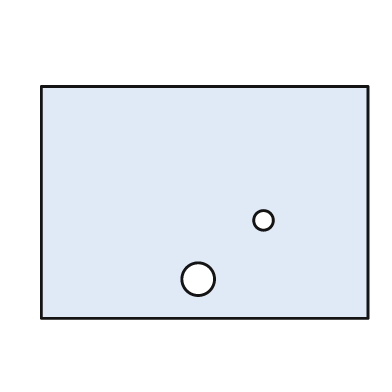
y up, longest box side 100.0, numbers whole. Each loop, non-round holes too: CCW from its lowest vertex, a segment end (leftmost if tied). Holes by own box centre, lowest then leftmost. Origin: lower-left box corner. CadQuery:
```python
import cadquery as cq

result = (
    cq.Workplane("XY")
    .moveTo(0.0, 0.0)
    .lineTo(100.0, 0.0)
    .lineTo(100.0, 71.0)
    .lineTo(0.0, 71.0)
    .close()
    .moveTo(48.0, 12.0)
    .circle(5.0)
    .moveTo(68.0, 30.0)
    .circle(3.0)
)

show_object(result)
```